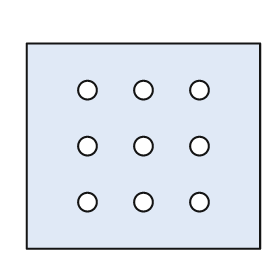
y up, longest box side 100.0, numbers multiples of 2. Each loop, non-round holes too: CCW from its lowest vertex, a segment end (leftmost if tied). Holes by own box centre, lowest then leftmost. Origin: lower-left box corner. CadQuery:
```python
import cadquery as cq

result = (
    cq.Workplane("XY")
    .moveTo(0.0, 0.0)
    .lineTo(100.0, 0.0)
    .lineTo(100.0, 88.0)
    .lineTo(0.0, 88.0)
    .close()
    .moveTo(26.0, 20.0)
    .circle(4.0)
    .moveTo(50.0, 20.0)
    .circle(4.0)
    .moveTo(74.0, 20.0)
    .circle(4.0)
    .moveTo(26.0, 44.0)
    .circle(4.0)
    .moveTo(50.0, 44.0)
    .circle(4.0)
    .moveTo(74.0, 44.0)
    .circle(4.0)
    .moveTo(26.0, 68.0)
    .circle(4.0)
    .moveTo(50.0, 68.0)
    .circle(4.0)
    .moveTo(74.0, 68.0)
    .circle(4.0)
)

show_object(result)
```